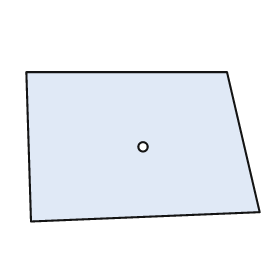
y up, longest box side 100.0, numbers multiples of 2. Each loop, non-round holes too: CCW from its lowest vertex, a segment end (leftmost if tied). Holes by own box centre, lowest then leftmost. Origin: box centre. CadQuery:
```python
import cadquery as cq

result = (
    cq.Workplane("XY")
    .moveTo(-48.0, -32.0)
    .lineTo(50.0, -28.0)
    .lineTo(36.0, 32.0)
    .lineTo(-50.0, 32.0)
    .close()
    .moveTo(0.0, 0.0)
    .circle(2.0)
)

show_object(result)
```